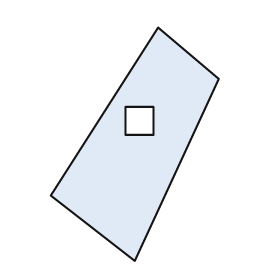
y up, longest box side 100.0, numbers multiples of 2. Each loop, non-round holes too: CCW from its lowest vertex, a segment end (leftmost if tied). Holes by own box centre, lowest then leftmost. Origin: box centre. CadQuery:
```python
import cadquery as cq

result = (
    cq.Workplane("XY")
    .moveTo(0.0, -50.0)
    .lineTo(36.0, 28.0)
    .lineTo(10.0, 50.0)
    .lineTo(-36.0, -22.0)
    .close()
    .moveTo(-4.0, 4.0)
    .lineTo(8.0, 4.0)
    .lineTo(8.0, 16.0)
    .lineTo(-4.0, 16.0)
    .close()
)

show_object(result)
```